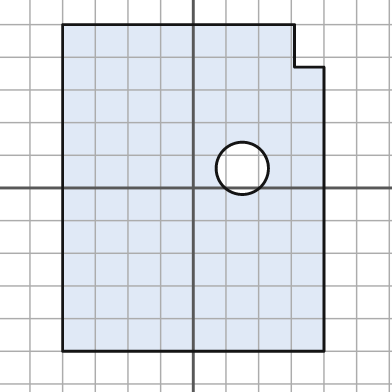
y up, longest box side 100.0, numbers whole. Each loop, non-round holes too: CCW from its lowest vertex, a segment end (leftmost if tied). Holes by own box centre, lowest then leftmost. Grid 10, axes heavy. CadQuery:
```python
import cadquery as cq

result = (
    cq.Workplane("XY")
    .moveTo(-40.0, -50.0)
    .lineTo(40.0, -50.0)
    .lineTo(40.0, 37.0)
    .lineTo(31.0, 37.0)
    .lineTo(31.0, 50.0)
    .lineTo(-40.0, 50.0)
    .close()
    .moveTo(15.0, 6.0)
    .circle(8.0)
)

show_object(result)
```